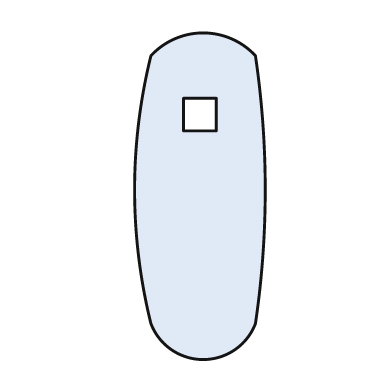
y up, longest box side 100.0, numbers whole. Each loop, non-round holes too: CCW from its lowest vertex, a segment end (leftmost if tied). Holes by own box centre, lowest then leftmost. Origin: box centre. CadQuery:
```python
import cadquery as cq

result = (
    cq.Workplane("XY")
    .moveTo(-15.0, -39.0)
    .threePointArc((1.0, -50.0), (17.0, -39.0))
    .threePointArc((20.0, 2.0), (17.0, 43.0))
    .threePointArc((1.0, 50.0), (-15.0, 43.0))
    .threePointArc((-20.0, 2.0), (-15.0, -39.0))
    .close()
    .moveTo(-5.0, 20.0)
    .lineTo(5.0, 20.0)
    .lineTo(5.0, 30.0)
    .lineTo(-5.0, 30.0)
    .close()
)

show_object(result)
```